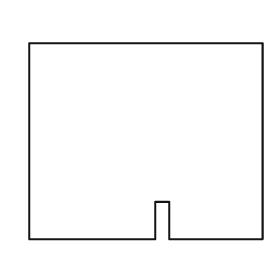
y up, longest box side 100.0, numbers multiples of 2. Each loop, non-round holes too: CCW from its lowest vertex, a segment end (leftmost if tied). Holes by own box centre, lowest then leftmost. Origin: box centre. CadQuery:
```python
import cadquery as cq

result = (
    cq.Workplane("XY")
    .moveTo(-50.0, -42.0)
    .lineTo(4.0, -42.0)
    .lineTo(4.0, -26.0)
    .lineTo(10.0, -26.0)
    .lineTo(10.0, -42.0)
    .lineTo(50.0, -42.0)
    .lineTo(50.0, 42.0)
    .lineTo(-50.0, 42.0)
    .close()
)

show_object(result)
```